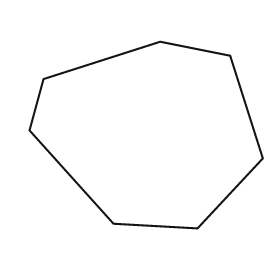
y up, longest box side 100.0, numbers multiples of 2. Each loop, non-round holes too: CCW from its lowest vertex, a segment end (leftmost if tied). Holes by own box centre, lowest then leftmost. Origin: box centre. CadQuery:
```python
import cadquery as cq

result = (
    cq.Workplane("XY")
    .moveTo(22.0, -40.0)
    .lineTo(50.0, -10.0)
    .lineTo(36.0, 34.0)
    .lineTo(6.0, 40.0)
    .lineTo(-44.0, 24.0)
    .lineTo(-50.0, 2.0)
    .lineTo(-14.0, -38.0)
    .close()
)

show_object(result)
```